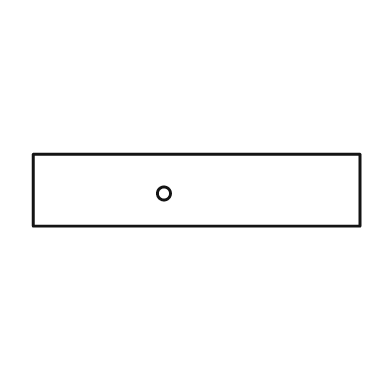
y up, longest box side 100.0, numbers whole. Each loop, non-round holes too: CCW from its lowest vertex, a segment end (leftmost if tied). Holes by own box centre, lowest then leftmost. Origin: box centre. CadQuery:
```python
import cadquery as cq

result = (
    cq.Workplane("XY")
    .moveTo(-50.0, -11.0)
    .lineTo(50.0, -11.0)
    .lineTo(50.0, 11.0)
    .lineTo(-50.0, 11.0)
    .close()
    .moveTo(-10.0, -1.0)
    .circle(2.0)
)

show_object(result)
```